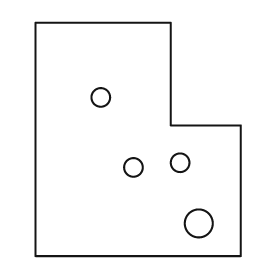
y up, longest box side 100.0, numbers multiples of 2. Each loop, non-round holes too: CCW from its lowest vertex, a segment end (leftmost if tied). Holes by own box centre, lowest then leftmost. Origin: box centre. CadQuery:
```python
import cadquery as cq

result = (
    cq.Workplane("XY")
    .moveTo(-44.0, -50.0)
    .lineTo(44.0, -50.0)
    .lineTo(44.0, 6.0)
    .lineTo(14.0, 6.0)
    .lineTo(14.0, 50.0)
    .lineTo(-44.0, 50.0)
    .close()
    .moveTo(26.0, -36.0)
    .circle(6.0)
    .moveTo(-2.0, -12.0)
    .circle(4.0)
    .moveTo(18.0, -10.0)
    .circle(4.0)
    .moveTo(-16.0, 18.0)
    .circle(4.0)
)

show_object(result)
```